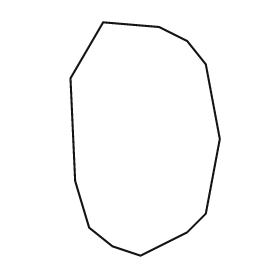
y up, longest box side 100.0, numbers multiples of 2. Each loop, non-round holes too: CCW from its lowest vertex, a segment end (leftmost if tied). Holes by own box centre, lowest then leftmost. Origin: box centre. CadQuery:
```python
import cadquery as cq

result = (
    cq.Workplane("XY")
    .moveTo(-2.0, -50.0)
    .lineTo(18.0, -40.0)
    .lineTo(26.0, -32.0)
    .lineTo(32.0, 0.0)
    .lineTo(26.0, 32.0)
    .lineTo(18.0, 42.0)
    .lineTo(6.0, 48.0)
    .lineTo(-18.0, 50.0)
    .lineTo(-32.0, 26.0)
    .lineTo(-30.0, -18.0)
    .lineTo(-24.0, -38.0)
    .lineTo(-14.0, -46.0)
    .close()
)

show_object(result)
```